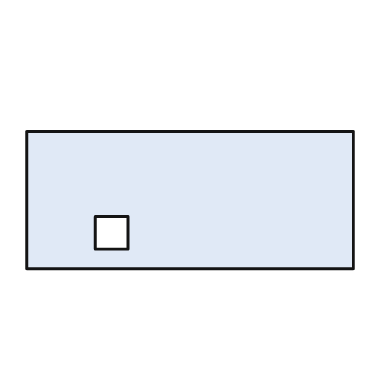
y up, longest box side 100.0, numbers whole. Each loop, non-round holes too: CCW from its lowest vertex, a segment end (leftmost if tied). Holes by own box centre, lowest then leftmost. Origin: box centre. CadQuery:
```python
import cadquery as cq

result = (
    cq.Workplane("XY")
    .moveTo(-50.0, -21.0)
    .lineTo(50.0, -21.0)
    .lineTo(50.0, 21.0)
    .lineTo(-50.0, 21.0)
    .close()
    .moveTo(-29.0, -15.0)
    .lineTo(-19.0, -15.0)
    .lineTo(-19.0, -5.0)
    .lineTo(-29.0, -5.0)
    .close()
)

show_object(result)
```